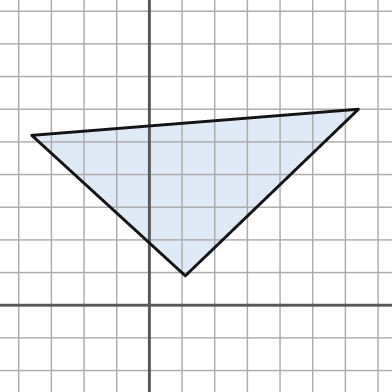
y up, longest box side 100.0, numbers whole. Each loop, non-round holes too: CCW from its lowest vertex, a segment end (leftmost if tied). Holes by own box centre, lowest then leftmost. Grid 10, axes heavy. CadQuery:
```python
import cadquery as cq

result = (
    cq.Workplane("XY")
    .moveTo(11.0, 9.0)
    .lineTo(64.0, 60.0)
    .lineTo(-36.0, 52.0)
    .close()
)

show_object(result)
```